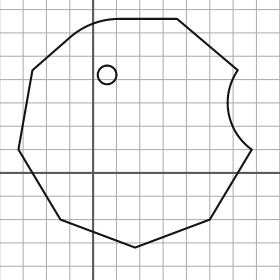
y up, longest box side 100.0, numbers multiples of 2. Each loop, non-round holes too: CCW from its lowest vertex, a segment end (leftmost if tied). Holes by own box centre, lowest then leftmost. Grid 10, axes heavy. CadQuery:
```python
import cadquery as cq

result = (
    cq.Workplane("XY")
    .moveTo(18.0, -32.0)
    .lineTo(50.0, -20.0)
    .lineTo(68.0, 10.0)
    .threePointArc((58.0, 26.0), (62.0, 44.0))
    .lineTo(36.0, 66.0)
    .lineTo(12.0, 66.0)
    .threePointArc((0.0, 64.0), (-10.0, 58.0))
    .lineTo(-26.0, 44.0)
    .lineTo(-32.0, 10.0)
    .lineTo(-14.0, -20.0)
    .close()
    .moveTo(6.0, 42.0)
    .circle(4.0)
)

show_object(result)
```